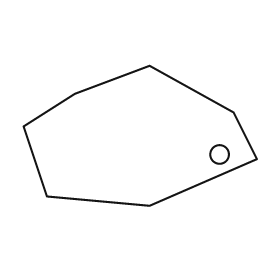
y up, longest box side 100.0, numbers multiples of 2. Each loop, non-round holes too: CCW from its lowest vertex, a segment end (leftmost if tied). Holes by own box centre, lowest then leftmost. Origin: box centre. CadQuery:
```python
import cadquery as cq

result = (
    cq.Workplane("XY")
    .moveTo(4.0, -30.0)
    .lineTo(50.0, -10.0)
    .lineTo(40.0, 10.0)
    .lineTo(4.0, 30.0)
    .lineTo(-28.0, 18.0)
    .lineTo(-50.0, 4.0)
    .lineTo(-40.0, -26.0)
    .close()
    .moveTo(34.0, -8.0)
    .circle(4.0)
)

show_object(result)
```